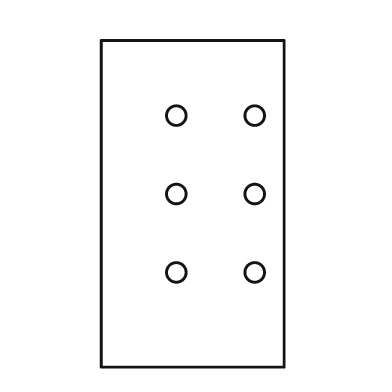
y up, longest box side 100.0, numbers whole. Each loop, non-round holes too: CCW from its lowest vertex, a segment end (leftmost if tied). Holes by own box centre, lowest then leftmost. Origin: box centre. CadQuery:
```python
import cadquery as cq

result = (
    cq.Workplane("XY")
    .moveTo(-28.0, -50.0)
    .lineTo(28.0, -50.0)
    .lineTo(28.0, 50.0)
    .lineTo(-28.0, 50.0)
    .close()
    .moveTo(-5.0, -21.0)
    .circle(3.0)
    .moveTo(19.0, -21.0)
    .circle(3.0)
    .moveTo(-5.0, 3.0)
    .circle(3.0)
    .moveTo(19.0, 3.0)
    .circle(3.0)
    .moveTo(-5.0, 27.0)
    .circle(3.0)
    .moveTo(19.0, 27.0)
    .circle(3.0)
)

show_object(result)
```